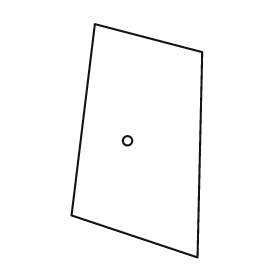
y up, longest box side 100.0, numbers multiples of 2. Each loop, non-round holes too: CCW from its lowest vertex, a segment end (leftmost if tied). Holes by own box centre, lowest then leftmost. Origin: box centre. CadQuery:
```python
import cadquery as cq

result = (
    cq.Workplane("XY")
    .moveTo(26.0, -50.0)
    .lineTo(28.0, 38.0)
    .lineTo(-18.0, 50.0)
    .lineTo(-28.0, -32.0)
    .close()
    .moveTo(-4.0, 0.0)
    .circle(2.0)
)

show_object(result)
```